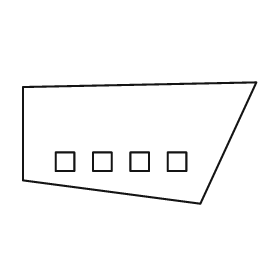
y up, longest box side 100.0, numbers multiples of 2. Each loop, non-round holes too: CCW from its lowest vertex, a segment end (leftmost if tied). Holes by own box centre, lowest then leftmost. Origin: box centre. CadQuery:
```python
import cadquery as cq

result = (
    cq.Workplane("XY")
    .moveTo(26.0, -26.0)
    .lineTo(50.0, 26.0)
    .lineTo(-50.0, 24.0)
    .lineTo(-50.0, -16.0)
    .close()
    .moveTo(-36.0, -12.0)
    .lineTo(-28.0, -12.0)
    .lineTo(-28.0, -4.0)
    .lineTo(-36.0, -4.0)
    .close()
    .moveTo(-20.0, -12.0)
    .lineTo(-12.0, -12.0)
    .lineTo(-12.0, -4.0)
    .lineTo(-20.0, -4.0)
    .close()
    .moveTo(-4.0, -12.0)
    .lineTo(4.0, -12.0)
    .lineTo(4.0, -4.0)
    .lineTo(-4.0, -4.0)
    .close()
    .moveTo(12.0, -12.0)
    .lineTo(20.0, -12.0)
    .lineTo(20.0, -4.0)
    .lineTo(12.0, -4.0)
    .close()
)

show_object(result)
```